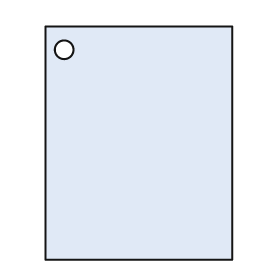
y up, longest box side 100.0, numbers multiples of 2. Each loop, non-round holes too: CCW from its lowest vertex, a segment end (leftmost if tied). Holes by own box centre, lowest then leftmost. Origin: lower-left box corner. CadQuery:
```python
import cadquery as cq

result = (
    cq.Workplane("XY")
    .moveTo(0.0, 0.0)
    .lineTo(80.0, 0.0)
    .lineTo(80.0, 100.0)
    .lineTo(0.0, 100.0)
    .close()
    .moveTo(8.0, 90.0)
    .circle(4.0)
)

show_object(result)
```